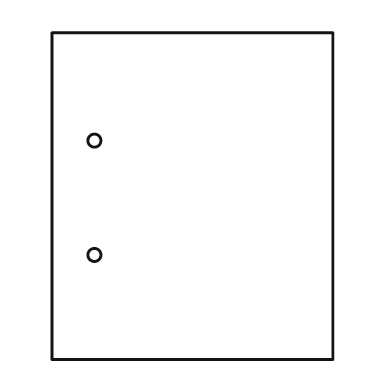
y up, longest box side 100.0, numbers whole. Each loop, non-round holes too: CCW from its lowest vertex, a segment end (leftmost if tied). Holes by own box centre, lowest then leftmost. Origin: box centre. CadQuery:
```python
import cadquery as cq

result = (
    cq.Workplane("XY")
    .moveTo(-43.0, -50.0)
    .lineTo(43.0, -50.0)
    .lineTo(43.0, 50.0)
    .lineTo(-43.0, 50.0)
    .close()
    .moveTo(-30.0, -18.0)
    .circle(2.0)
    .moveTo(-30.0, 17.0)
    .circle(2.0)
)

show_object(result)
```